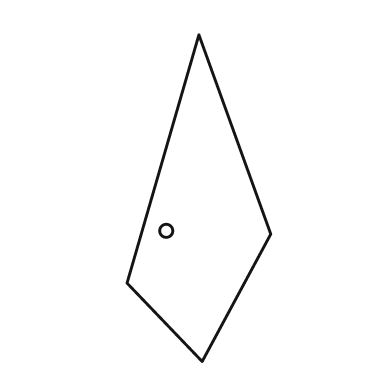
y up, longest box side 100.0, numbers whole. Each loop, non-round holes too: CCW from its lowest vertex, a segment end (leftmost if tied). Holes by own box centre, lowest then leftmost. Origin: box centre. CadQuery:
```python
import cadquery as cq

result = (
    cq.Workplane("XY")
    .moveTo(1.0, -50.0)
    .lineTo(22.0, -11.0)
    .lineTo(0.0, 50.0)
    .lineTo(-22.0, -26.0)
    .close()
    .moveTo(-10.0, -10.0)
    .circle(2.0)
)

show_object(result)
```